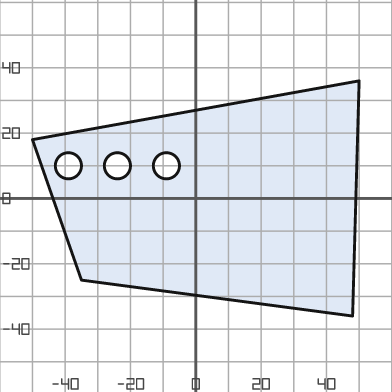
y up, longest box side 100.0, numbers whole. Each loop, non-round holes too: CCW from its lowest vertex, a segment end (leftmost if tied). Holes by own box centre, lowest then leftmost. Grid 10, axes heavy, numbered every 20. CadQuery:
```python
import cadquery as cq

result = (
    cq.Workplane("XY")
    .moveTo(48.0, -36.0)
    .lineTo(50.0, 36.0)
    .lineTo(-50.0, 18.0)
    .lineTo(-35.0, -25.0)
    .close()
    .moveTo(-39.0, 10.0)
    .circle(4.0)
    .moveTo(-24.0, 10.0)
    .circle(4.0)
    .moveTo(-9.0, 10.0)
    .circle(4.0)
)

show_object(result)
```